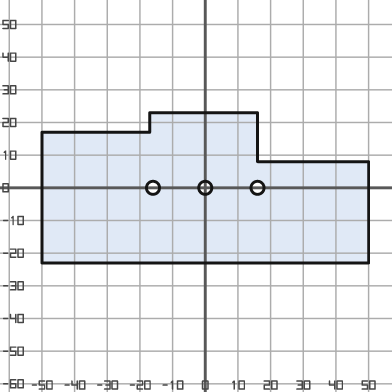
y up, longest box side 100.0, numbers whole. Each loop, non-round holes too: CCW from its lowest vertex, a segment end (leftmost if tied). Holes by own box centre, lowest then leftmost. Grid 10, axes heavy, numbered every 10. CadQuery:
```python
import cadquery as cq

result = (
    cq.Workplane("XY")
    .moveTo(-50.0, -23.0)
    .lineTo(50.0, -23.0)
    .lineTo(50.0, 8.0)
    .lineTo(16.0, 8.0)
    .lineTo(16.0, 23.0)
    .lineTo(-17.0, 23.0)
    .lineTo(-17.0, 17.0)
    .lineTo(-50.0, 17.0)
    .close()
    .moveTo(-16.0, 0.0)
    .circle(2.0)
    .moveTo(0.0, 0.0)
    .circle(2.0)
    .moveTo(16.0, 0.0)
    .circle(2.0)
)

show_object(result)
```